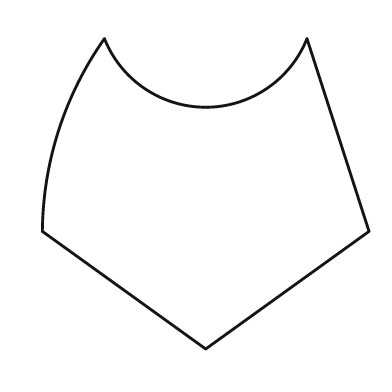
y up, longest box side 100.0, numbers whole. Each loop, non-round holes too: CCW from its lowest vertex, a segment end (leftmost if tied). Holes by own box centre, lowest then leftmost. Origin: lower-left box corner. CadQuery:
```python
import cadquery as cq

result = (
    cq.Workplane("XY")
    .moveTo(50.0, 0.0)
    .lineTo(100.0, 36.0)
    .lineTo(81.0, 95.0)
    .threePointArc((50.0, 74.0), (19.0, 95.0))
    .threePointArc((5.0, 67.0), (0.0, 36.0))
    .close()
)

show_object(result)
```